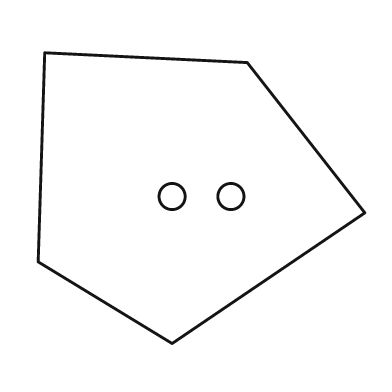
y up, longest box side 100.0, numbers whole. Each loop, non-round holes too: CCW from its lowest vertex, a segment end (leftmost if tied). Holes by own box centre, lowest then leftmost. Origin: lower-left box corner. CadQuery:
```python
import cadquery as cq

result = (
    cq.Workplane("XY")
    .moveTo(41.0, 0.0)
    .lineTo(100.0, 40.0)
    .lineTo(64.0, 86.0)
    .lineTo(2.0, 89.0)
    .lineTo(0.0, 25.0)
    .close()
    .moveTo(41.0, 45.0)
    .circle(4.0)
    .moveTo(59.0, 45.0)
    .circle(4.0)
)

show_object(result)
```